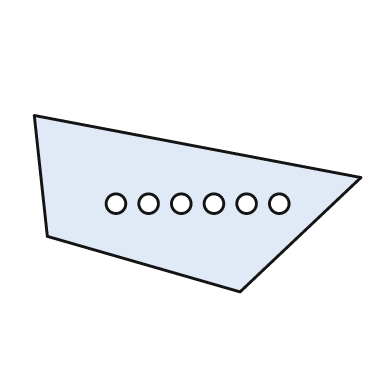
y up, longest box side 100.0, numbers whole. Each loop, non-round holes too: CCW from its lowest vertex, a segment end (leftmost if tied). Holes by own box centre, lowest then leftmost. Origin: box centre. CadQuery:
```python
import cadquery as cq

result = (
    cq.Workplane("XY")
    .moveTo(13.0, -27.0)
    .lineTo(50.0, 8.0)
    .lineTo(-50.0, 27.0)
    .lineTo(-46.0, -10.0)
    .close()
    .moveTo(-25.0, 0.0)
    .circle(3.0)
    .moveTo(-15.0, 0.0)
    .circle(3.0)
    .moveTo(-5.0, 0.0)
    .circle(3.0)
    .moveTo(5.0, 0.0)
    .circle(3.0)
    .moveTo(15.0, 0.0)
    .circle(3.0)
    .moveTo(25.0, 0.0)
    .circle(3.0)
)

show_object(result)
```